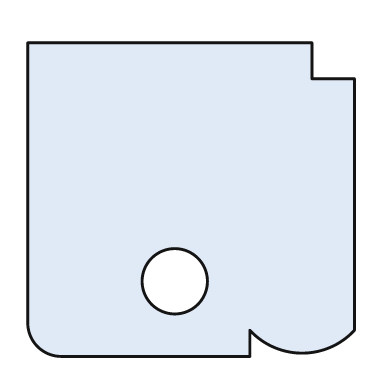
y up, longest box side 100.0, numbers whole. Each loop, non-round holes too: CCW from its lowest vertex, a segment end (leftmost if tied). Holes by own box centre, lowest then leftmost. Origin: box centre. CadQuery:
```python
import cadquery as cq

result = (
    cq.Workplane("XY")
    .moveTo(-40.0, -48.0)
    .lineTo(18.0, -48.0)
    .lineTo(18.0, -40.0)
    .threePointArc((34.0, -47.0), (50.0, -40.0))
    .lineTo(50.0, 37.0)
    .lineTo(37.0, 37.0)
    .lineTo(37.0, 48.0)
    .lineTo(-50.0, 48.0)
    .lineTo(-50.0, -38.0)
    .threePointArc((-47.0, -45.0), (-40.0, -48.0))
    .close()
    .moveTo(-5.0, -25.0)
    .circle(10.0)
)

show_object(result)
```